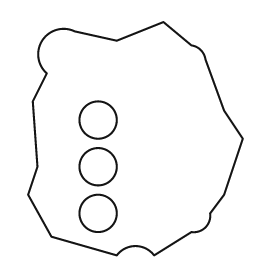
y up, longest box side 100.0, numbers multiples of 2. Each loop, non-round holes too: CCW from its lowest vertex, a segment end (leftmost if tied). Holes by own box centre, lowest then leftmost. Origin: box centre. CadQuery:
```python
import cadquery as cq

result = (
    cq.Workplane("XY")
    .moveTo(-8.0, -50.0)
    .threePointArc((0.0, -46.0), (8.0, -50.0))
    .lineTo(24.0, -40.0)
    .threePointArc((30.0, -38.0), (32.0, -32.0))
    .lineTo(38.0, -24.0)
    .lineTo(46.0, 0.0)
    .lineTo(38.0, 12.0)
    .lineTo(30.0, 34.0)
    .threePointArc((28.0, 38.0), (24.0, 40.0))
    .lineTo(12.0, 50.0)
    .lineTo(-8.0, 42.0)
    .lineTo(-26.0, 46.0)
    .threePointArc((-40.0, 42.0), (-38.0, 28.0))
    .lineTo(-44.0, 16.0)
    .lineTo(-42.0, -12.0)
    .lineTo(-46.0, -24.0)
    .lineTo(-36.0, -42.0)
    .close()
    .moveTo(-16.0, -32.0)
    .circle(8.0)
    .moveTo(-16.0, -12.0)
    .circle(8.0)
    .moveTo(-16.0, 8.0)
    .circle(8.0)
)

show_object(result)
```